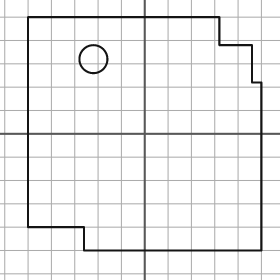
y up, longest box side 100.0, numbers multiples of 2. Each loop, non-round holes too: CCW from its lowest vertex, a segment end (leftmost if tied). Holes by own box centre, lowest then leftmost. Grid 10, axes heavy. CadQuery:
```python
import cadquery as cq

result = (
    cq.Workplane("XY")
    .moveTo(-26.0, -50.0)
    .lineTo(50.0, -50.0)
    .lineTo(50.0, 22.0)
    .lineTo(46.0, 22.0)
    .lineTo(46.0, 38.0)
    .lineTo(32.0, 38.0)
    .lineTo(32.0, 50.0)
    .lineTo(-50.0, 50.0)
    .lineTo(-50.0, -40.0)
    .lineTo(-26.0, -40.0)
    .close()
    .moveTo(-22.0, 32.0)
    .circle(6.0)
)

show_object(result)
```